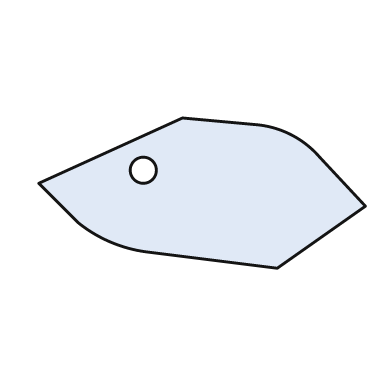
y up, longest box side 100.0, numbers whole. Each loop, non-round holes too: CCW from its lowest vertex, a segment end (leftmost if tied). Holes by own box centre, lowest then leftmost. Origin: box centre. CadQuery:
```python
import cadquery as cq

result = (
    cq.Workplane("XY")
    .moveTo(23.0, -23.0)
    .lineTo(50.0, -4.0)
    .lineTo(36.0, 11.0)
    .threePointArc((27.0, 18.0), (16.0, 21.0))
    .lineTo(-6.0, 23.0)
    .lineTo(-50.0, 3.0)
    .lineTo(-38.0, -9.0)
    .threePointArc((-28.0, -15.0), (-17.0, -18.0))
    .close()
    .moveTo(-18.0, 7.0)
    .circle(4.0)
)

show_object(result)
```